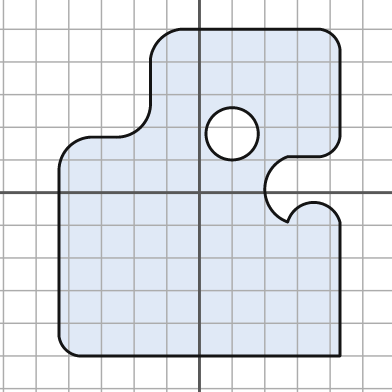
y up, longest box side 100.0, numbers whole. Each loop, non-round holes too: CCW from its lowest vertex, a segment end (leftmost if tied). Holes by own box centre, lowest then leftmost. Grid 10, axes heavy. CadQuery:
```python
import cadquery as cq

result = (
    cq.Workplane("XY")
    .moveTo(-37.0, -50.0)
    .lineTo(43.0, -50.0)
    .lineTo(43.0, -9.0)
    .threePointArc((35.0, -3.0), (27.0, -9.0))
    .threePointArc((20.0, 1.0), (27.0, 11.0))
    .lineTo(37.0, 11.0)
    .threePointArc((41.0, 13.0), (43.0, 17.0))
    .lineTo(43.0, 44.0)
    .threePointArc((41.0, 48.0), (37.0, 50.0))
    .lineTo(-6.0, 50.0)
    .threePointArc((-12.0, 47.0), (-15.0, 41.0))
    .lineTo(-15.0, 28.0)
    .threePointArc((-18.0, 20.0), (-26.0, 17.0))
    .lineTo(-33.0, 17.0)
    .threePointArc((-40.0, 14.0), (-43.0, 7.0))
    .lineTo(-43.0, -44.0)
    .threePointArc((-41.0, -48.0), (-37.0, -50.0))
    .close()
    .moveTo(10.0, 18.0)
    .circle(8.0)
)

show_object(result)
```